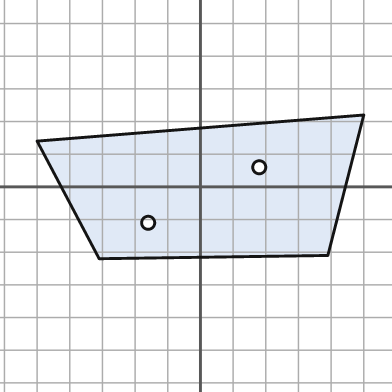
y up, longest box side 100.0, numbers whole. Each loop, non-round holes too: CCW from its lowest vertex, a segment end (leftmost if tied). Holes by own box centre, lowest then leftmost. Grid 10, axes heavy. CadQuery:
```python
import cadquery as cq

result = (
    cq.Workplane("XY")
    .moveTo(-31.0, -22.0)
    .lineTo(39.0, -21.0)
    .lineTo(50.0, 22.0)
    .lineTo(-50.0, 14.0)
    .close()
    .moveTo(-16.0, -11.0)
    .circle(2.0)
    .moveTo(18.0, 6.0)
    .circle(2.0)
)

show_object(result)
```